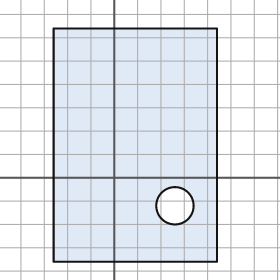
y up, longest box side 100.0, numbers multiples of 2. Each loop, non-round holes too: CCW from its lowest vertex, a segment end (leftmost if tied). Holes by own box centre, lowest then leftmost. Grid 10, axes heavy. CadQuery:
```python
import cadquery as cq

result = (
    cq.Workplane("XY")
    .moveTo(-26.0, -36.0)
    .lineTo(44.0, -36.0)
    .lineTo(44.0, 64.0)
    .lineTo(-26.0, 64.0)
    .close()
    .moveTo(26.0, -12.0)
    .circle(8.0)
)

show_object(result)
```